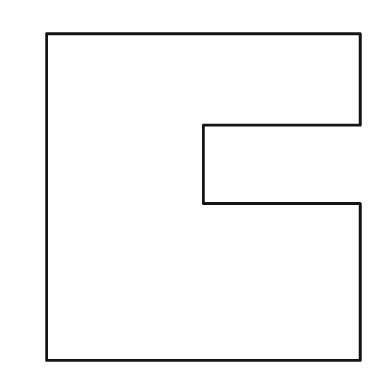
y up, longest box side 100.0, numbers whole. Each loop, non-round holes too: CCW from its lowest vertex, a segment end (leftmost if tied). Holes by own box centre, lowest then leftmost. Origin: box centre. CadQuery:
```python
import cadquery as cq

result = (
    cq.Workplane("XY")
    .moveTo(-48.0, -50.0)
    .lineTo(48.0, -50.0)
    .lineTo(48.0, -2.0)
    .lineTo(0.0, -2.0)
    .lineTo(0.0, 22.0)
    .lineTo(48.0, 22.0)
    .lineTo(48.0, 50.0)
    .lineTo(-48.0, 50.0)
    .close()
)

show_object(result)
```